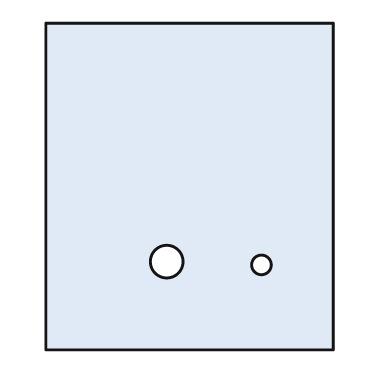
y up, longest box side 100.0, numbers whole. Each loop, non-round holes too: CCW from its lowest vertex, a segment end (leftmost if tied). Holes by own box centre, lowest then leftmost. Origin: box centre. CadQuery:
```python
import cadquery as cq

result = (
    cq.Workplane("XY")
    .moveTo(-44.0, -50.0)
    .lineTo(44.0, -50.0)
    .lineTo(44.0, 50.0)
    .lineTo(-44.0, 50.0)
    .close()
    .moveTo(22.0, -24.0)
    .circle(3.0)
    .moveTo(-7.0, -23.0)
    .circle(5.0)
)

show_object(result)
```